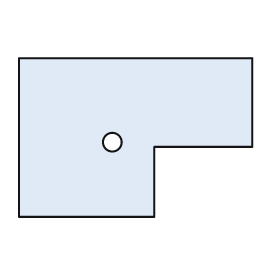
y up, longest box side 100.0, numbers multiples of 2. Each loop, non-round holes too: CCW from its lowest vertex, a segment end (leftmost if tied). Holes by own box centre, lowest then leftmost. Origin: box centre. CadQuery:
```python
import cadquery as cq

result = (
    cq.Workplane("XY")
    .moveTo(-50.0, -34.0)
    .lineTo(8.0, -34.0)
    .lineTo(8.0, -4.0)
    .lineTo(50.0, -4.0)
    .lineTo(50.0, 34.0)
    .lineTo(-50.0, 34.0)
    .close()
    .moveTo(-10.0, -2.0)
    .circle(4.0)
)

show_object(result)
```